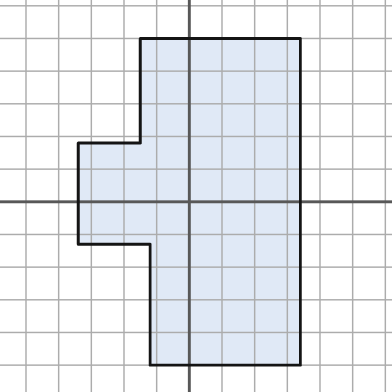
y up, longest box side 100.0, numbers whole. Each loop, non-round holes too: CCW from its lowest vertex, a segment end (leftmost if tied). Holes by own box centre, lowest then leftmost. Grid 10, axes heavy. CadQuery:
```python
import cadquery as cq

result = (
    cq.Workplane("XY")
    .moveTo(-12.0, -50.0)
    .lineTo(34.0, -50.0)
    .lineTo(34.0, 50.0)
    .lineTo(-15.0, 50.0)
    .lineTo(-15.0, 18.0)
    .lineTo(-34.0, 18.0)
    .lineTo(-34.0, -13.0)
    .lineTo(-12.0, -13.0)
    .close()
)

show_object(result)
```